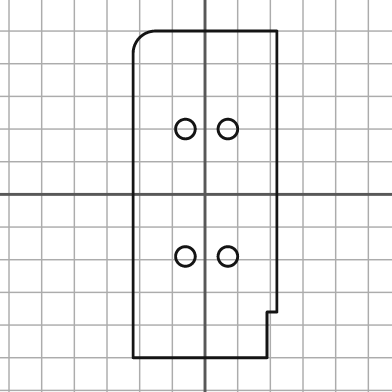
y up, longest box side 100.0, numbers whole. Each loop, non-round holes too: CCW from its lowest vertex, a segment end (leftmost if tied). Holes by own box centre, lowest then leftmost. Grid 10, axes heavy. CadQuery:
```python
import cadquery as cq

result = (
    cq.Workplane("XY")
    .moveTo(-22.0, -50.0)
    .lineTo(19.0, -50.0)
    .lineTo(19.0, -36.0)
    .lineTo(22.0, -36.0)
    .lineTo(22.0, 50.0)
    .lineTo(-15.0, 50.0)
    .threePointArc((-20.0, 48.0), (-22.0, 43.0))
    .close()
    .moveTo(-6.0, -19.0)
    .circle(3.0)
    .moveTo(7.0, -19.0)
    .circle(3.0)
    .moveTo(-6.0, 20.0)
    .circle(3.0)
    .moveTo(7.0, 20.0)
    .circle(3.0)
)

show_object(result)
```